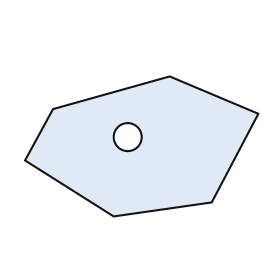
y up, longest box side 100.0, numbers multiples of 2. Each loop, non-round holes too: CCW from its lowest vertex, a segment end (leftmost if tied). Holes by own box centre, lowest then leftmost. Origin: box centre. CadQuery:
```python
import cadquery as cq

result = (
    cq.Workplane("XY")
    .moveTo(-12.0, -30.0)
    .lineTo(30.0, -24.0)
    .lineTo(50.0, 14.0)
    .lineTo(12.0, 30.0)
    .lineTo(-38.0, 16.0)
    .lineTo(-50.0, -6.0)
    .close()
    .moveTo(-6.0, 4.0)
    .circle(6.0)
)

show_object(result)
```